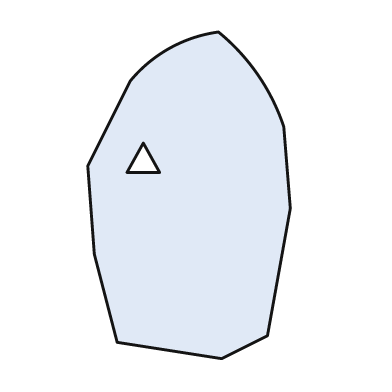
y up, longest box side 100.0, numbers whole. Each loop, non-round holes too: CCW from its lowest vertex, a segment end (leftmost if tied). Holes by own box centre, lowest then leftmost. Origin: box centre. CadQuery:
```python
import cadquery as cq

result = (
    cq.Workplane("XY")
    .moveTo(10.0, -50.0)
    .lineTo(24.0, -43.0)
    .lineTo(31.0, -4.0)
    .lineTo(29.0, 21.0)
    .threePointArc((21.0, 37.0), (9.0, 50.0))
    .threePointArc((-6.0, 45.0), (-18.0, 35.0))
    .lineTo(-31.0, 9.0)
    .lineTo(-29.0, -18.0)
    .lineTo(-22.0, -45.0)
    .close()
    .moveTo(-19.0, 7.0)
    .lineTo(-9.0, 7.0)
    .lineTo(-14.0, 16.0)
    .close()
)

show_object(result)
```